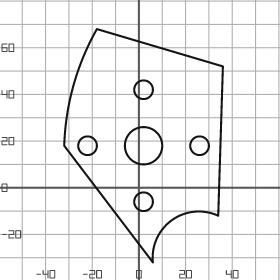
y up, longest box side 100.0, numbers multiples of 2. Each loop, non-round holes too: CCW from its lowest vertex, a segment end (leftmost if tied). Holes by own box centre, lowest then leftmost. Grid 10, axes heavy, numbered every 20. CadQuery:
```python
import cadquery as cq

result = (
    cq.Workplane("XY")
    .moveTo(6.0, -32.0)
    .threePointArc((14.0, -14.0), (34.0, -12.0))
    .lineTo(36.0, 52.0)
    .lineTo(-18.0, 68.0)
    .threePointArc((-28.0, 44.0), (-32.0, 18.0))
    .close()
    .moveTo(2.0, -6.0)
    .circle(4.0)
    .moveTo(-22.0, 18.0)
    .circle(4.0)
    .moveTo(2.0, 18.0)
    .circle(8.0)
    .moveTo(26.0, 18.0)
    .circle(4.0)
    .moveTo(2.0, 42.0)
    .circle(4.0)
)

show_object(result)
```